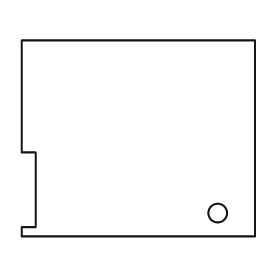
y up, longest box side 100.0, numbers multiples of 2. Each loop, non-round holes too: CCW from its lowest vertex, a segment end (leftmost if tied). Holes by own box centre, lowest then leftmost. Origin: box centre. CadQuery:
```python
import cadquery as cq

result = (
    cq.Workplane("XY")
    .moveTo(-50.0, -42.0)
    .lineTo(50.0, -42.0)
    .lineTo(50.0, 42.0)
    .lineTo(-50.0, 42.0)
    .lineTo(-50.0, -6.0)
    .lineTo(-44.0, -6.0)
    .lineTo(-44.0, -38.0)
    .lineTo(-50.0, -38.0)
    .close()
    .moveTo(34.0, -32.0)
    .circle(4.0)
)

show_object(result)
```